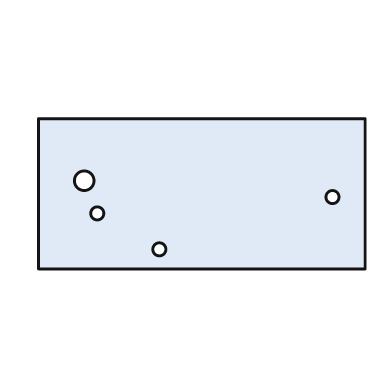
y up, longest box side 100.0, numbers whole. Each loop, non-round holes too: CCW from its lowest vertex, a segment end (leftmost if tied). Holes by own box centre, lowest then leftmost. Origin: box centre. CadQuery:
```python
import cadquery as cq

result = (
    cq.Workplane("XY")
    .moveTo(-50.0, -23.0)
    .lineTo(50.0, -23.0)
    .lineTo(50.0, 23.0)
    .lineTo(-50.0, 23.0)
    .close()
    .moveTo(-13.0, -17.0)
    .circle(2.0)
    .moveTo(-32.0, -6.0)
    .circle(2.0)
    .moveTo(40.0, -1.0)
    .circle(2.0)
    .moveTo(-36.0, 4.0)
    .circle(3.0)
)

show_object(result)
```